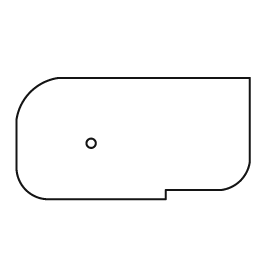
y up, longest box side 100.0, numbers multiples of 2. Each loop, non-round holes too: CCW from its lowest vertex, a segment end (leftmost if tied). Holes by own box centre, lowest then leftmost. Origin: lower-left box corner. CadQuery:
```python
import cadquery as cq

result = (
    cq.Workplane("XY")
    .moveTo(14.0, 0.0)
    .lineTo(64.0, 0.0)
    .lineTo(64.0, 4.0)
    .lineTo(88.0, 4.0)
    .threePointArc((96.0, 8.0), (100.0, 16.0))
    .lineTo(100.0, 52.0)
    .lineTo(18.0, 52.0)
    .threePointArc((6.0, 46.0), (0.0, 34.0))
    .lineTo(0.0, 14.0)
    .threePointArc((4.0, 4.0), (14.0, 0.0))
    .close()
    .moveTo(32.0, 24.0)
    .circle(2.0)
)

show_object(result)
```